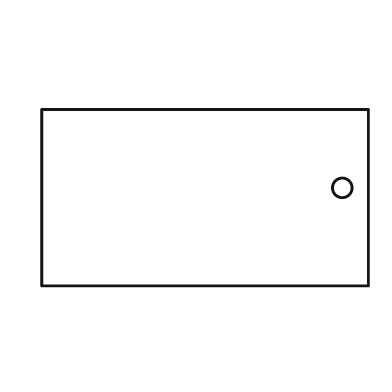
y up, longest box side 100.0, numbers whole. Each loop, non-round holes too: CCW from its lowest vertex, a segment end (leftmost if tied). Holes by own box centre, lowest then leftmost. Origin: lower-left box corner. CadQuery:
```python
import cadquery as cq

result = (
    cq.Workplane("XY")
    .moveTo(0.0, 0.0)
    .lineTo(100.0, 0.0)
    .lineTo(100.0, 54.0)
    .lineTo(0.0, 54.0)
    .close()
    .moveTo(92.0, 30.0)
    .circle(3.0)
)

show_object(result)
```